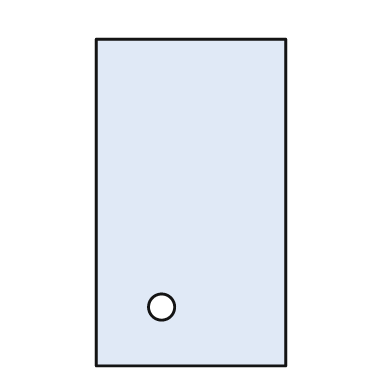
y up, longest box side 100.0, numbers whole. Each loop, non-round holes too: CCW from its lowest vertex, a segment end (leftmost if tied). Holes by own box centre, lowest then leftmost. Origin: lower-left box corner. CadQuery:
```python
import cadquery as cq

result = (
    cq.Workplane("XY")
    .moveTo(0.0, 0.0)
    .lineTo(58.0, 0.0)
    .lineTo(58.0, 100.0)
    .lineTo(0.0, 100.0)
    .close()
    .moveTo(20.0, 18.0)
    .circle(4.0)
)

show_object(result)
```